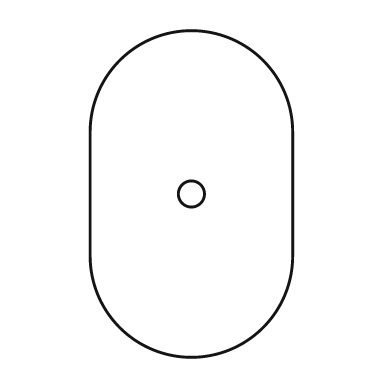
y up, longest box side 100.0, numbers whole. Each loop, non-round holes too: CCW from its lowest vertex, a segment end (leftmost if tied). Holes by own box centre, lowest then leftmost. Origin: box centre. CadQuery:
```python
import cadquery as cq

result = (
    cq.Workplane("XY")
    .moveTo(-31.0, -19.0)
    .threePointArc((0.0, -50.0), (31.0, -19.0))
    .lineTo(31.0, 19.0)
    .threePointArc((0.0, 50.0), (-31.0, 19.0))
    .close()
    .moveTo(0.0, 0.0)
    .circle(4.0)
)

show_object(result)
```